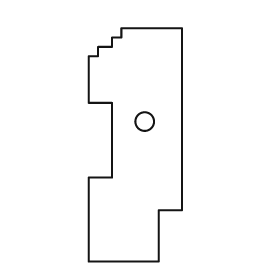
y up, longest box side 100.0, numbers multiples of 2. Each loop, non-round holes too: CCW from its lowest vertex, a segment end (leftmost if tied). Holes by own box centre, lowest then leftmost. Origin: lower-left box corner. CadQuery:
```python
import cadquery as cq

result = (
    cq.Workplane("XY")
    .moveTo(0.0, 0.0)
    .lineTo(30.0, 0.0)
    .lineTo(30.0, 22.0)
    .lineTo(40.0, 22.0)
    .lineTo(40.0, 100.0)
    .lineTo(14.0, 100.0)
    .lineTo(14.0, 96.0)
    .lineTo(10.0, 96.0)
    .lineTo(10.0, 92.0)
    .lineTo(4.0, 92.0)
    .lineTo(4.0, 88.0)
    .lineTo(0.0, 88.0)
    .lineTo(0.0, 68.0)
    .lineTo(10.0, 68.0)
    .lineTo(10.0, 36.0)
    .lineTo(0.0, 36.0)
    .close()
    .moveTo(24.0, 60.0)
    .circle(4.0)
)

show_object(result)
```